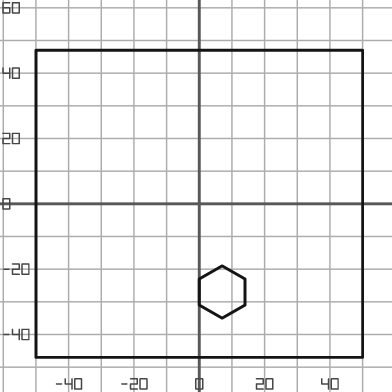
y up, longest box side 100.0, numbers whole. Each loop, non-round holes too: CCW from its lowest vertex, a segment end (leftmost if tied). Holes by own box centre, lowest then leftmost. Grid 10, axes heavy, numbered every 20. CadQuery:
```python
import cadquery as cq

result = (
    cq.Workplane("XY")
    .moveTo(-50.0, -47.0)
    .lineTo(50.0, -47.0)
    .lineTo(50.0, 47.0)
    .lineTo(-50.0, 47.0)
    .close()
    .moveTo(7.0, -35.0)
    .lineTo(14.0, -31.0)
    .lineTo(14.0, -23.0)
    .lineTo(7.0, -19.0)
    .lineTo(0.0, -23.0)
    .lineTo(0.0, -31.0)
    .close()
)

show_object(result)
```